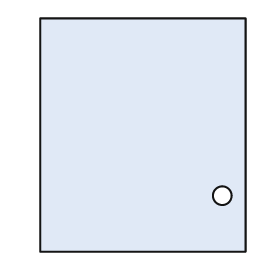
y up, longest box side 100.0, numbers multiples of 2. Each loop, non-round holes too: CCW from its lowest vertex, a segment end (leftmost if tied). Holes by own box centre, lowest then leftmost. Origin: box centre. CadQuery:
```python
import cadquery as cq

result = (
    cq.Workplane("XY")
    .moveTo(-44.0, -50.0)
    .lineTo(44.0, -50.0)
    .lineTo(44.0, 50.0)
    .lineTo(-44.0, 50.0)
    .close()
    .moveTo(34.0, -26.0)
    .circle(4.0)
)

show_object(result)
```